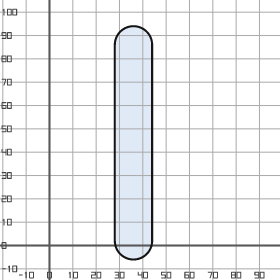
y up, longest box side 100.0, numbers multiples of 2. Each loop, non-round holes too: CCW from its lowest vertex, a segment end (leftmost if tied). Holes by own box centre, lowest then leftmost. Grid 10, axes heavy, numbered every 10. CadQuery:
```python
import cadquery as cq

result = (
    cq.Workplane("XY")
    .moveTo(28.0, 2.0)
    .threePointArc((36.0, -6.0), (44.0, 2.0))
    .lineTo(44.0, 86.0)
    .threePointArc((36.0, 94.0), (28.0, 86.0))
    .close()
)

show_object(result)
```